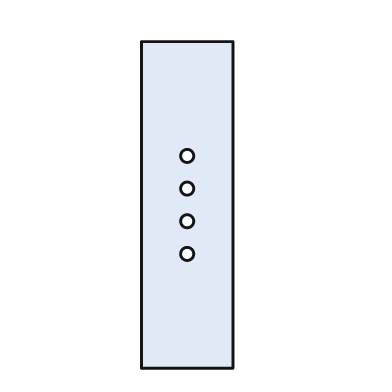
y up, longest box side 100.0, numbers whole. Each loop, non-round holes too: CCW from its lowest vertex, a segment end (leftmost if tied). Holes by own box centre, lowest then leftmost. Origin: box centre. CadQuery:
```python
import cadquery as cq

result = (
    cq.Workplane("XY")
    .moveTo(-14.0, -50.0)
    .lineTo(14.0, -50.0)
    .lineTo(14.0, 50.0)
    .lineTo(-14.0, 50.0)
    .close()
    .moveTo(0.0, -15.0)
    .circle(2.0)
    .moveTo(0.0, -5.0)
    .circle(2.0)
    .moveTo(0.0, 5.0)
    .circle(2.0)
    .moveTo(0.0, 15.0)
    .circle(2.0)
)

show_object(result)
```